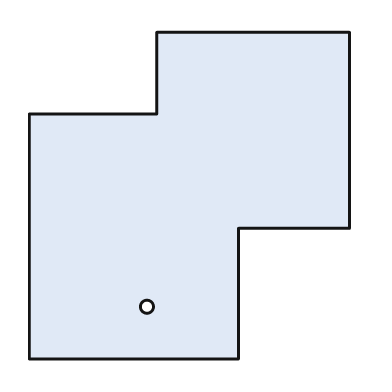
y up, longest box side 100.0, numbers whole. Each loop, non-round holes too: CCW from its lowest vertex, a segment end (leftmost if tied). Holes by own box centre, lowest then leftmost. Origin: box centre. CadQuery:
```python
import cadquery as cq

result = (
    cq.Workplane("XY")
    .moveTo(-49.0, -50.0)
    .lineTo(15.0, -50.0)
    .lineTo(15.0, -10.0)
    .lineTo(49.0, -10.0)
    .lineTo(49.0, 50.0)
    .lineTo(-10.0, 50.0)
    .lineTo(-10.0, 25.0)
    .lineTo(-49.0, 25.0)
    .close()
    .moveTo(-13.0, -34.0)
    .circle(2.0)
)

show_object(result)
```